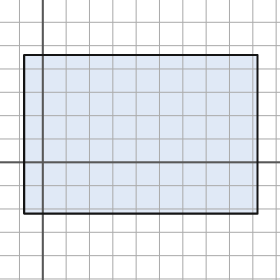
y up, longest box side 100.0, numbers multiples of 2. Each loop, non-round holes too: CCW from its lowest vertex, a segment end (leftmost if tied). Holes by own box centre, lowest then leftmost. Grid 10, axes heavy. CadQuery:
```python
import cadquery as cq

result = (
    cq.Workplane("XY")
    .moveTo(-8.0, -22.0)
    .lineTo(92.0, -22.0)
    .lineTo(92.0, 46.0)
    .lineTo(-8.0, 46.0)
    .close()
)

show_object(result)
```